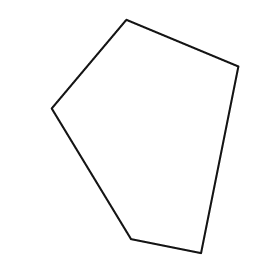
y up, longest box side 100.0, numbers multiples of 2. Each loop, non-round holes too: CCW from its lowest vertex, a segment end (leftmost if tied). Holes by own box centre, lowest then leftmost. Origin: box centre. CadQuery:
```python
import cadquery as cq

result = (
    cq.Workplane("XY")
    .moveTo(24.0, -50.0)
    .lineTo(40.0, 30.0)
    .lineTo(-8.0, 50.0)
    .lineTo(-40.0, 12.0)
    .lineTo(-6.0, -44.0)
    .close()
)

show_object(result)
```